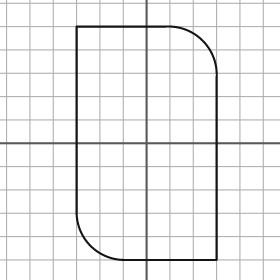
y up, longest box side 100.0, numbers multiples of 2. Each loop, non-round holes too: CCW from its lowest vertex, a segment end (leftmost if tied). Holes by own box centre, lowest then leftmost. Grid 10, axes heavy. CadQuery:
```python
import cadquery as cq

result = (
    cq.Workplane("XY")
    .moveTo(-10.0, -50.0)
    .lineTo(30.0, -50.0)
    .lineTo(30.0, 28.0)
    .threePointArc((24.0, 44.0), (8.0, 50.0))
    .lineTo(-30.0, 50.0)
    .lineTo(-30.0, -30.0)
    .threePointArc((-24.0, -44.0), (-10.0, -50.0))
    .close()
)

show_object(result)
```